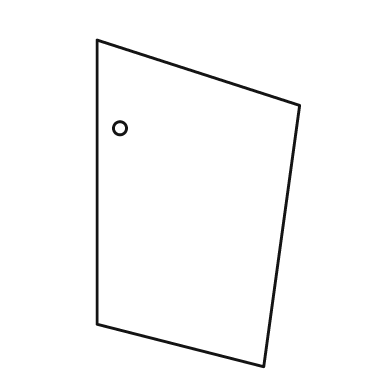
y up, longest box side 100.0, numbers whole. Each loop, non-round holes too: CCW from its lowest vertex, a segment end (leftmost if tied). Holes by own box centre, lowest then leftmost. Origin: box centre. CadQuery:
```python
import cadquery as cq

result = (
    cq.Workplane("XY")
    .moveTo(20.0, -50.0)
    .lineTo(31.0, 30.0)
    .lineTo(-31.0, 50.0)
    .lineTo(-31.0, -37.0)
    .close()
    .moveTo(-24.0, 23.0)
    .circle(2.0)
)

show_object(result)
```